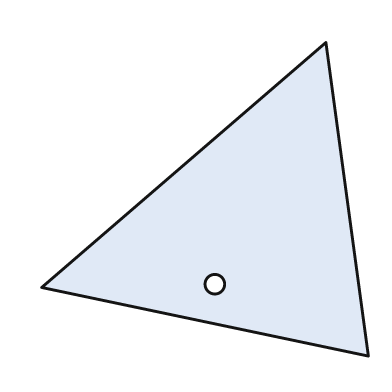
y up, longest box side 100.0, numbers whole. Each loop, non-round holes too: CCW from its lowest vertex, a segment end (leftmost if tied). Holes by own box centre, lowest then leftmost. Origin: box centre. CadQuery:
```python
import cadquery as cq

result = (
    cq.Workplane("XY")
    .moveTo(50.0, -48.0)
    .lineTo(37.0, 48.0)
    .lineTo(-50.0, -27.0)
    .close()
    .moveTo(3.0, -26.0)
    .circle(3.0)
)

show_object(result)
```